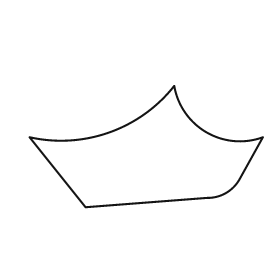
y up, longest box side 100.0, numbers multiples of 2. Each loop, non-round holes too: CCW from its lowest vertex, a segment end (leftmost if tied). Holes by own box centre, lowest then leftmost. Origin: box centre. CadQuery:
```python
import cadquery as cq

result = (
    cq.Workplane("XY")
    .moveTo(-26.0, -26.0)
    .lineTo(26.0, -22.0)
    .threePointArc((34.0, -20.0), (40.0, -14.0))
    .lineTo(50.0, 4.0)
    .threePointArc((26.0, 6.0), (12.0, 26.0))
    .threePointArc((-16.0, 6.0), (-50.0, 4.0))
    .close()
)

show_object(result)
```